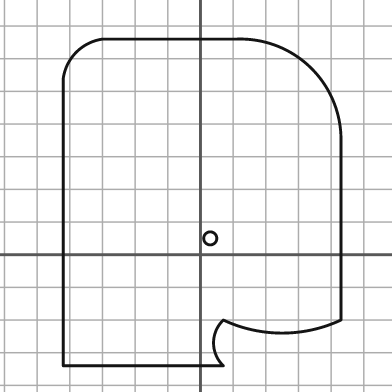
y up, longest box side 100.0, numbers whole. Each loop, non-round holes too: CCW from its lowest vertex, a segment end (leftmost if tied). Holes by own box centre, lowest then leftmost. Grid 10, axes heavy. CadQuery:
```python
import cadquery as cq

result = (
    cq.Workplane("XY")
    .moveTo(-42.0, -34.0)
    .lineTo(7.0, -34.0)
    .threePointArc((4.0, -27.0), (7.0, -20.0))
    .threePointArc((25.0, -24.0), (43.0, -20.0))
    .lineTo(43.0, 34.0)
    .threePointArc((34.0, 57.0), (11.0, 66.0))
    .lineTo(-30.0, 66.0)
    .threePointArc((-38.0, 62.0), (-42.0, 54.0))
    .close()
    .moveTo(3.0, 5.0)
    .circle(2.0)
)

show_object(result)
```